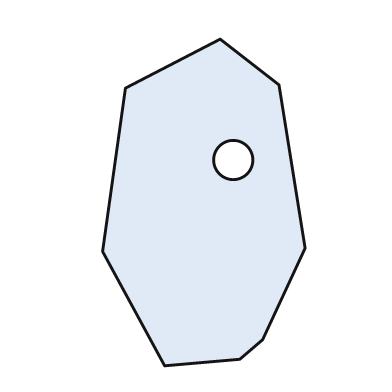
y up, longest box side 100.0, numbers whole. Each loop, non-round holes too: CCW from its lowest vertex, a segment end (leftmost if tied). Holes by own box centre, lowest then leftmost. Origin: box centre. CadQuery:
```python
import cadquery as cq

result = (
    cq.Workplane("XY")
    .moveTo(-12.0, -50.0)
    .lineTo(11.0, -48.0)
    .lineTo(18.0, -42.0)
    .lineTo(31.0, -14.0)
    .lineTo(23.0, 36.0)
    .lineTo(5.0, 50.0)
    .lineTo(-24.0, 35.0)
    .lineTo(-31.0, -15.0)
    .close()
    .moveTo(9.0, 13.0)
    .circle(6.0)
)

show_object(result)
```